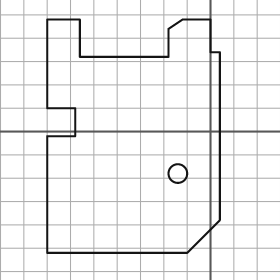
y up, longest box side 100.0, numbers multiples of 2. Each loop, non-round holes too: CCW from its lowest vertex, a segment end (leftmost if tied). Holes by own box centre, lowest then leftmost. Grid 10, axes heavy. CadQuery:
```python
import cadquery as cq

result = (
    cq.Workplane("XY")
    .moveTo(-70.0, -52.0)
    .lineTo(-10.0, -52.0)
    .lineTo(4.0, -38.0)
    .lineTo(4.0, 34.0)
    .lineTo(0.0, 34.0)
    .lineTo(0.0, 48.0)
    .lineTo(-12.0, 48.0)
    .lineTo(-18.0, 44.0)
    .lineTo(-18.0, 32.0)
    .lineTo(-56.0, 32.0)
    .lineTo(-56.0, 48.0)
    .lineTo(-70.0, 48.0)
    .lineTo(-70.0, 10.0)
    .lineTo(-58.0, 10.0)
    .lineTo(-58.0, -2.0)
    .lineTo(-70.0, -2.0)
    .close()
    .moveTo(-14.0, -18.0)
    .circle(4.0)
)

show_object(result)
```